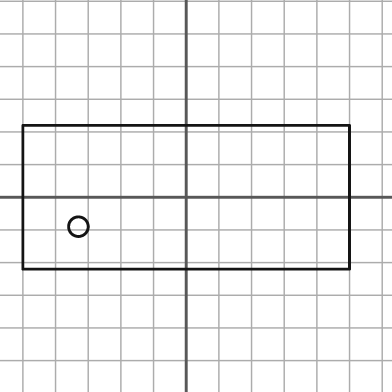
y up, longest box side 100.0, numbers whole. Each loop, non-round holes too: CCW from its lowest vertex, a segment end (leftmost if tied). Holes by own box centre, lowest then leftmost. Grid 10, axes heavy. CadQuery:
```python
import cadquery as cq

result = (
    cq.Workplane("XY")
    .moveTo(-50.0, -22.0)
    .lineTo(50.0, -22.0)
    .lineTo(50.0, 22.0)
    .lineTo(-50.0, 22.0)
    .close()
    .moveTo(-33.0, -9.0)
    .circle(3.0)
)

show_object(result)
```